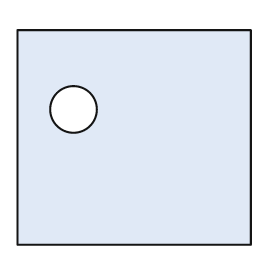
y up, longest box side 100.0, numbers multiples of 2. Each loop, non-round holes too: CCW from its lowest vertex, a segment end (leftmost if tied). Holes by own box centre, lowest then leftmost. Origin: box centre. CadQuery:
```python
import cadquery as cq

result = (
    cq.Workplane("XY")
    .moveTo(-50.0, -46.0)
    .lineTo(50.0, -46.0)
    .lineTo(50.0, 46.0)
    .lineTo(-50.0, 46.0)
    .close()
    .moveTo(-26.0, 12.0)
    .circle(10.0)
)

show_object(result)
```